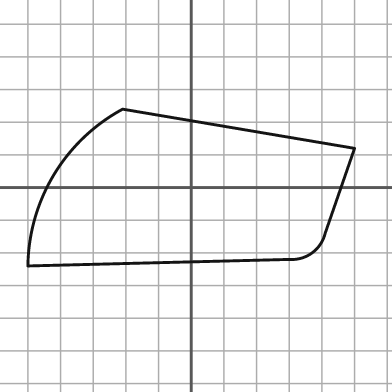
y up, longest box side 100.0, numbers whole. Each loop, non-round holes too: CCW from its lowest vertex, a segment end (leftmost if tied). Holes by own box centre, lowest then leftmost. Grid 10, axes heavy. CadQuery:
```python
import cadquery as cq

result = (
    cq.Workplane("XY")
    .moveTo(-50.0, -24.0)
    .lineTo(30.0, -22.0)
    .threePointArc((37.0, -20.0), (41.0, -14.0))
    .lineTo(50.0, 12.0)
    .lineTo(-21.0, 24.0)
    .threePointArc((-42.0, 4.0), (-50.0, -24.0))
    .close()
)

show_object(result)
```